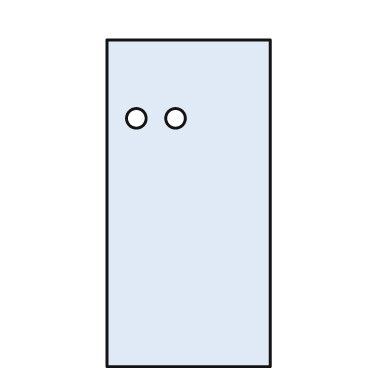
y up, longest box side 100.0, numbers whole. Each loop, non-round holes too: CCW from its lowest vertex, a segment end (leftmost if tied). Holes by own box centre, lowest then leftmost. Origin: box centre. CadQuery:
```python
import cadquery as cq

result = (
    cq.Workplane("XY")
    .moveTo(-25.0, -50.0)
    .lineTo(25.0, -50.0)
    .lineTo(25.0, 50.0)
    .lineTo(-25.0, 50.0)
    .close()
    .moveTo(-16.0, 26.0)
    .circle(3.0)
    .moveTo(-4.0, 26.0)
    .circle(3.0)
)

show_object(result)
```